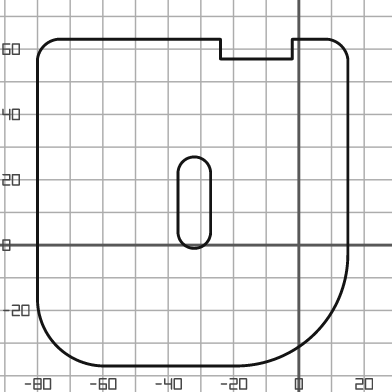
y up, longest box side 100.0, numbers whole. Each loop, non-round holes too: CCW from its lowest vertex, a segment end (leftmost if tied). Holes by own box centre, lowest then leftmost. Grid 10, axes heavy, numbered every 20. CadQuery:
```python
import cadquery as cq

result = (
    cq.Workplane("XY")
    .moveTo(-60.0, -37.0)
    .lineTo(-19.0, -37.0)
    .threePointArc((5.0, -27.0), (15.0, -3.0))
    .lineTo(15.0, 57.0)
    .threePointArc((13.0, 61.0), (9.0, 63.0))
    .lineTo(-2.0, 63.0)
    .lineTo(-2.0, 57.0)
    .lineTo(-24.0, 57.0)
    .lineTo(-24.0, 63.0)
    .lineTo(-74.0, 63.0)
    .threePointArc((-78.0, 61.0), (-80.0, 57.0))
    .lineTo(-80.0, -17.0)
    .threePointArc((-74.0, -31.0), (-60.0, -37.0))
    .close()
    .moveTo(-37.0, 4.0)
    .threePointArc((-32.0, -1.0), (-27.0, 4.0))
    .lineTo(-27.0, 22.0)
    .threePointArc((-32.0, 27.0), (-37.0, 22.0))
    .close()
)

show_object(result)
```